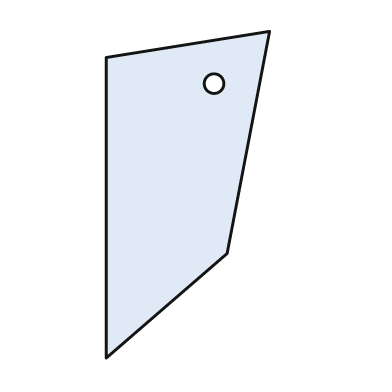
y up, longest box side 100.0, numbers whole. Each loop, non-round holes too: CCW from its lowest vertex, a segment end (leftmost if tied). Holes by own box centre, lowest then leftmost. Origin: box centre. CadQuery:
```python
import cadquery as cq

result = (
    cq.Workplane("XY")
    .moveTo(-25.0, -50.0)
    .lineTo(12.0, -18.0)
    .lineTo(25.0, 50.0)
    .lineTo(-25.0, 42.0)
    .close()
    .moveTo(8.0, 34.0)
    .circle(3.0)
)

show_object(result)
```